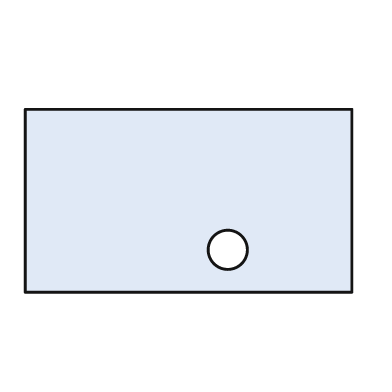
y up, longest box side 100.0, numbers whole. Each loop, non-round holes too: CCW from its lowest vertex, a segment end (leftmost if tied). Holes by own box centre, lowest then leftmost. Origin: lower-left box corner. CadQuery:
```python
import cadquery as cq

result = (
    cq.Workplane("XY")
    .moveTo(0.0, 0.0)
    .lineTo(100.0, 0.0)
    .lineTo(100.0, 56.0)
    .lineTo(0.0, 56.0)
    .close()
    .moveTo(62.0, 13.0)
    .circle(6.0)
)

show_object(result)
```